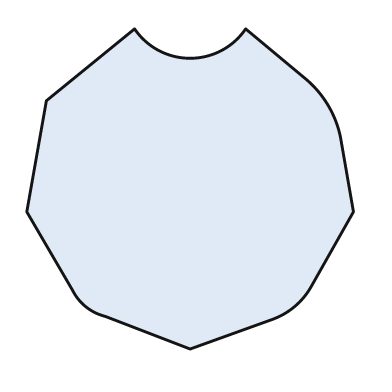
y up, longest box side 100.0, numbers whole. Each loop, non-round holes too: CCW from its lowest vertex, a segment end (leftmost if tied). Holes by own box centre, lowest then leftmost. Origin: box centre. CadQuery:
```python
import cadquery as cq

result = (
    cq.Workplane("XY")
    .moveTo(0.0, -49.0)
    .lineTo(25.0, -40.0)
    .threePointArc((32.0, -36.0), (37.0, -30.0))
    .lineTo(50.0, -7.0)
    .lineTo(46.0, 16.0)
    .threePointArc((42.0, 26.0), (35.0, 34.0))
    .lineTo(17.0, 49.0)
    .threePointArc((0.0, 40.0), (-17.0, 49.0))
    .lineTo(-44.0, 27.0)
    .lineTo(-50.0, -7.0)
    .lineTo(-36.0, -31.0)
    .threePointArc((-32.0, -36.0), (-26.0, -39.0))
    .close()
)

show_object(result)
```